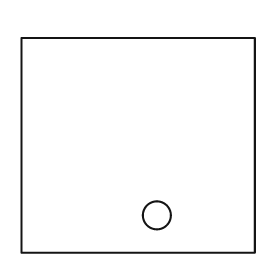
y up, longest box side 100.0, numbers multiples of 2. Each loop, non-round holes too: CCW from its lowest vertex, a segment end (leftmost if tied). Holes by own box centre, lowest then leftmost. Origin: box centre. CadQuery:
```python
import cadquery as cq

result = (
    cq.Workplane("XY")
    .moveTo(-50.0, -46.0)
    .lineTo(50.0, -46.0)
    .lineTo(50.0, 46.0)
    .lineTo(-50.0, 46.0)
    .close()
    .moveTo(8.0, -30.0)
    .circle(6.0)
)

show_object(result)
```